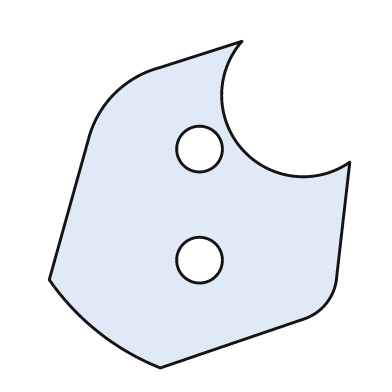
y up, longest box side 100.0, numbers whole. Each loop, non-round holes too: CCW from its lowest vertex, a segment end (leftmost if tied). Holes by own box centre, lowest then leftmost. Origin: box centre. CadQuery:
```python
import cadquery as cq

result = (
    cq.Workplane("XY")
    .moveTo(-12.0, -50.0)
    .lineTo(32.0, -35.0)
    .threePointArc((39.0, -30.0), (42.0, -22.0))
    .lineTo(46.0, 13.0)
    .threePointArc((13.0, 17.0), (13.0, 50.0))
    .lineTo(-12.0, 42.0)
    .threePointArc((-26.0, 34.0), (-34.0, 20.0))
    .lineTo(-46.0, -23.0)
    .threePointArc((-31.0, -39.0), (-12.0, -50.0))
    .close()
    .moveTo(0.0, -17.0)
    .circle(7.0)
    .moveTo(0.0, 17.0)
    .circle(7.0)
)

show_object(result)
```